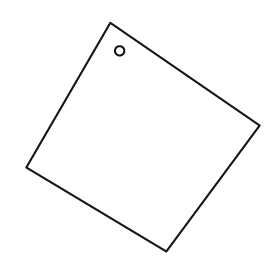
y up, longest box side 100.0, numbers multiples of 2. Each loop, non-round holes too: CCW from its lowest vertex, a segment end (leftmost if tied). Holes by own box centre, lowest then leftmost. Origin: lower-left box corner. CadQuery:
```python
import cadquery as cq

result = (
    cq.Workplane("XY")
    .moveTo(60.0, 0.0)
    .lineTo(100.0, 54.0)
    .lineTo(36.0, 98.0)
    .lineTo(0.0, 36.0)
    .close()
    .moveTo(40.0, 86.0)
    .circle(2.0)
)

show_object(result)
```